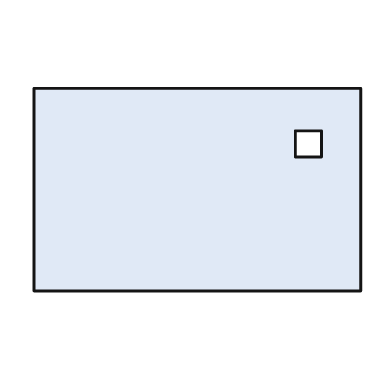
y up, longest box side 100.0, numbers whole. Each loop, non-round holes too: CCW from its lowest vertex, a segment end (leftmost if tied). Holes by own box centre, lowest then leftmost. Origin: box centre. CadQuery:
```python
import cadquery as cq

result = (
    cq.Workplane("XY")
    .moveTo(-50.0, -31.0)
    .lineTo(50.0, -31.0)
    .lineTo(50.0, 31.0)
    .lineTo(-50.0, 31.0)
    .close()
    .moveTo(30.0, 10.0)
    .lineTo(38.0, 10.0)
    .lineTo(38.0, 18.0)
    .lineTo(30.0, 18.0)
    .close()
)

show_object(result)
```